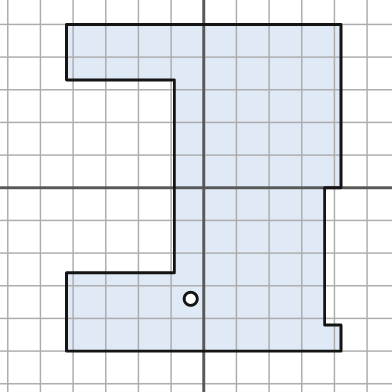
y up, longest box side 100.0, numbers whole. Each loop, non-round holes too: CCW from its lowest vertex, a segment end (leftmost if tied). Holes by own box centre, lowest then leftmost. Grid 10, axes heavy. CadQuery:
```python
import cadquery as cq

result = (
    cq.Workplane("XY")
    .moveTo(-42.0, -50.0)
    .lineTo(42.0, -50.0)
    .lineTo(42.0, -42.0)
    .lineTo(37.0, -42.0)
    .lineTo(37.0, 0.0)
    .lineTo(42.0, 0.0)
    .lineTo(42.0, 50.0)
    .lineTo(-42.0, 50.0)
    .lineTo(-42.0, 33.0)
    .lineTo(-9.0, 33.0)
    .lineTo(-9.0, -26.0)
    .lineTo(-42.0, -26.0)
    .close()
    .moveTo(-4.0, -34.0)
    .circle(2.0)
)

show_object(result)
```